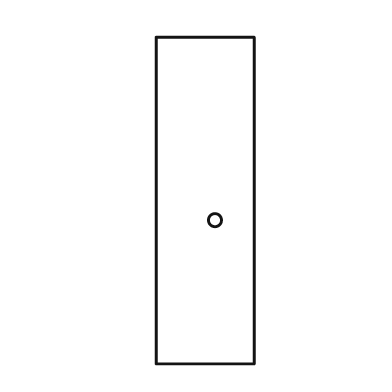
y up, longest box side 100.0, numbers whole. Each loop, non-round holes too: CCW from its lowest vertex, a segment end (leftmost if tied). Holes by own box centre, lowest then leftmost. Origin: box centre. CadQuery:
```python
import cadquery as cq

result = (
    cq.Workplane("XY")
    .moveTo(-15.0, -50.0)
    .lineTo(15.0, -50.0)
    .lineTo(15.0, 50.0)
    .lineTo(-15.0, 50.0)
    .close()
    .moveTo(3.0, -6.0)
    .circle(2.0)
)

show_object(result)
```